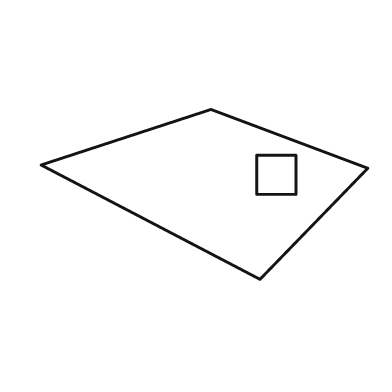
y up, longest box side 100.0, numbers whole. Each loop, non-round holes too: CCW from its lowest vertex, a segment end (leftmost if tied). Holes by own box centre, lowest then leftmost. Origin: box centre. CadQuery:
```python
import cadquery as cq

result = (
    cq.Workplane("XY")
    .moveTo(17.0, -26.0)
    .lineTo(50.0, 8.0)
    .lineTo(2.0, 26.0)
    .lineTo(-50.0, 9.0)
    .close()
    .moveTo(16.0, 0.0)
    .lineTo(28.0, 0.0)
    .lineTo(28.0, 12.0)
    .lineTo(16.0, 12.0)
    .close()
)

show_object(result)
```